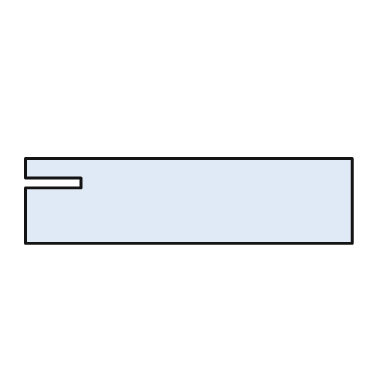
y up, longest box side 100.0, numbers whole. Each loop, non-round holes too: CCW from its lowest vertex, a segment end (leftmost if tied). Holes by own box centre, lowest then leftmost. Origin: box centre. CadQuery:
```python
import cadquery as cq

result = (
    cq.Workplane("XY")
    .moveTo(-50.0, -13.0)
    .lineTo(50.0, -13.0)
    .lineTo(50.0, 13.0)
    .lineTo(-50.0, 13.0)
    .lineTo(-50.0, 7.0)
    .lineTo(-33.0, 7.0)
    .lineTo(-33.0, 4.0)
    .lineTo(-50.0, 4.0)
    .close()
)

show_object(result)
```